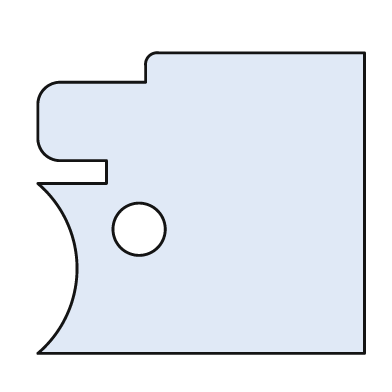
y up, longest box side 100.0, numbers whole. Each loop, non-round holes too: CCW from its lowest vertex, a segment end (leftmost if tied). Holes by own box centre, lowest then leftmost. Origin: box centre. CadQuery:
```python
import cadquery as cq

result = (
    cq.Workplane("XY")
    .moveTo(-50.0, -46.0)
    .lineTo(50.0, -46.0)
    .lineTo(50.0, 46.0)
    .lineTo(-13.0, 46.0)
    .threePointArc((-16.0, 45.0), (-17.0, 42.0))
    .lineTo(-17.0, 37.0)
    .lineTo(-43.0, 37.0)
    .threePointArc((-48.0, 35.0), (-50.0, 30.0))
    .lineTo(-50.0, 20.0)
    .threePointArc((-48.0, 15.0), (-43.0, 13.0))
    .lineTo(-29.0, 13.0)
    .lineTo(-29.0, 6.0)
    .lineTo(-50.0, 6.0)
    .threePointArc((-38.0, -20.0), (-50.0, -46.0))
    .close()
    .moveTo(-19.0, -8.0)
    .circle(8.0)
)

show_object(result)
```